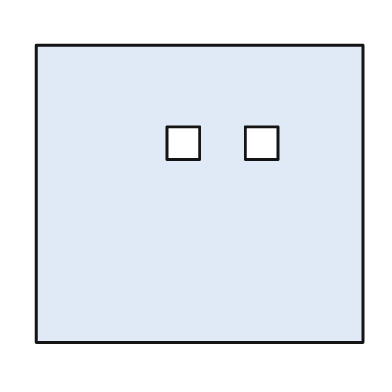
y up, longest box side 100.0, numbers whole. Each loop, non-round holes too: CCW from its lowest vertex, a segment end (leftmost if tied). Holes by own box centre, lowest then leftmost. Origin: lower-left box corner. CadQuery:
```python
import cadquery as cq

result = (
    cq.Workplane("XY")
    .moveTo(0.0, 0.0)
    .lineTo(100.0, 0.0)
    .lineTo(100.0, 91.0)
    .lineTo(0.0, 91.0)
    .close()
    .moveTo(40.0, 56.0)
    .lineTo(50.0, 56.0)
    .lineTo(50.0, 66.0)
    .lineTo(40.0, 66.0)
    .close()
    .moveTo(64.0, 56.0)
    .lineTo(74.0, 56.0)
    .lineTo(74.0, 66.0)
    .lineTo(64.0, 66.0)
    .close()
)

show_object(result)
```